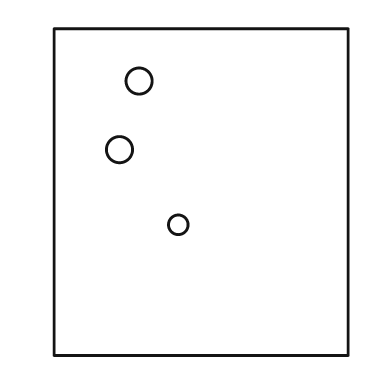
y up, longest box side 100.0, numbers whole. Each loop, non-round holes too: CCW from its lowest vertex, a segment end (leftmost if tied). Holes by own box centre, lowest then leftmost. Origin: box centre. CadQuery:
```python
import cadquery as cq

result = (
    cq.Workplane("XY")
    .moveTo(-45.0, -50.0)
    .lineTo(45.0, -50.0)
    .lineTo(45.0, 50.0)
    .lineTo(-45.0, 50.0)
    .close()
    .moveTo(-7.0, -10.0)
    .circle(3.0)
    .moveTo(-25.0, 13.0)
    .circle(4.0)
    .moveTo(-19.0, 34.0)
    .circle(4.0)
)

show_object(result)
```